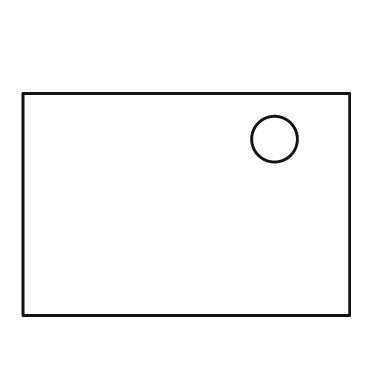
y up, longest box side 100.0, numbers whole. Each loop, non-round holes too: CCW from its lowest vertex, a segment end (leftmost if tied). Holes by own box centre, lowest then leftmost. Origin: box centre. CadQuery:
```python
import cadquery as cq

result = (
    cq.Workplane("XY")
    .moveTo(-50.0, -34.0)
    .lineTo(50.0, -34.0)
    .lineTo(50.0, 34.0)
    .lineTo(-50.0, 34.0)
    .close()
    .moveTo(27.0, 20.0)
    .circle(7.0)
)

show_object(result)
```